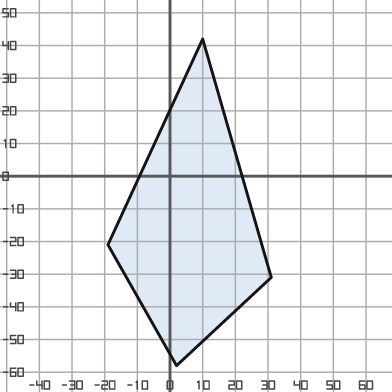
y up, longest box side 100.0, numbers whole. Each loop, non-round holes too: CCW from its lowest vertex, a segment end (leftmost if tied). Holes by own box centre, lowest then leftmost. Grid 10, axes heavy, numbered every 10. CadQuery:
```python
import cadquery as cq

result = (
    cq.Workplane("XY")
    .moveTo(2.0, -58.0)
    .lineTo(31.0, -31.0)
    .lineTo(10.0, 42.0)
    .lineTo(-19.0, -21.0)
    .close()
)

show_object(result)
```